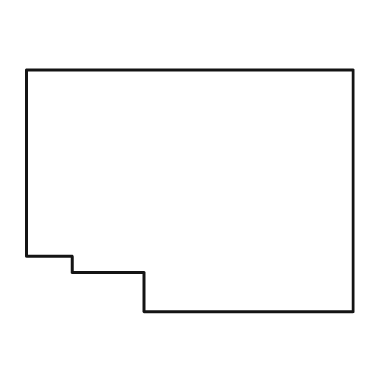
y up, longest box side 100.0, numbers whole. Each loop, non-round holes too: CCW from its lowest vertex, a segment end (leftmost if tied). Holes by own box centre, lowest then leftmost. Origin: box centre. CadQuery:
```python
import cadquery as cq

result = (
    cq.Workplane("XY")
    .moveTo(-14.0, -37.0)
    .lineTo(50.0, -37.0)
    .lineTo(50.0, 37.0)
    .lineTo(-50.0, 37.0)
    .lineTo(-50.0, -20.0)
    .lineTo(-36.0, -20.0)
    .lineTo(-36.0, -25.0)
    .lineTo(-14.0, -25.0)
    .close()
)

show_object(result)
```